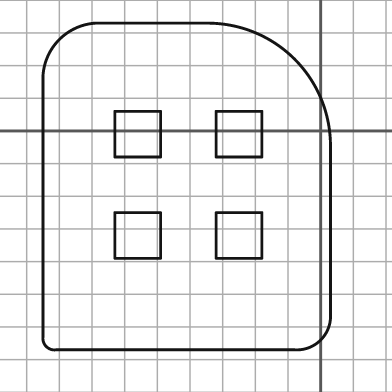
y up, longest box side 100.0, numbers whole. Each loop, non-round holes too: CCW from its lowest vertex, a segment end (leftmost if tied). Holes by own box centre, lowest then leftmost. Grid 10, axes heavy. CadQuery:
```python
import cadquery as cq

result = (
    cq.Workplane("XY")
    .moveTo(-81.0, -67.0)
    .lineTo(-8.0, -67.0)
    .threePointArc((0.0, -64.0), (3.0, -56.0))
    .lineTo(3.0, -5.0)
    .threePointArc((-8.0, 22.0), (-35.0, 33.0))
    .lineTo(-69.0, 33.0)
    .threePointArc((-80.0, 28.0), (-85.0, 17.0))
    .lineTo(-85.0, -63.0)
    .threePointArc((-84.0, -66.0), (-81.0, -67.0))
    .close()
    .moveTo(-63.0, -39.0)
    .lineTo(-49.0, -39.0)
    .lineTo(-49.0, -25.0)
    .lineTo(-63.0, -25.0)
    .close()
    .moveTo(-32.0, -39.0)
    .lineTo(-18.0, -39.0)
    .lineTo(-18.0, -25.0)
    .lineTo(-32.0, -25.0)
    .close()
    .moveTo(-63.0, -8.0)
    .lineTo(-49.0, -8.0)
    .lineTo(-49.0, 6.0)
    .lineTo(-63.0, 6.0)
    .close()
    .moveTo(-32.0, -8.0)
    .lineTo(-18.0, -8.0)
    .lineTo(-18.0, 6.0)
    .lineTo(-32.0, 6.0)
    .close()
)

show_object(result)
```